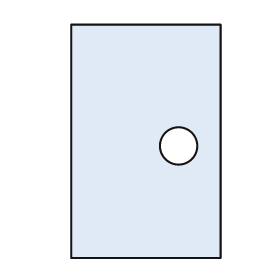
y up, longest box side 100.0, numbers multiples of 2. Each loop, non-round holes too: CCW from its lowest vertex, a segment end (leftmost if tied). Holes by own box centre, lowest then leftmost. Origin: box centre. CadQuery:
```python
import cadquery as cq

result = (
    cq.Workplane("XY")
    .moveTo(-32.0, -50.0)
    .lineTo(32.0, -50.0)
    .lineTo(32.0, 50.0)
    .lineTo(-32.0, 50.0)
    .close()
    .moveTo(14.0, -2.0)
    .circle(8.0)
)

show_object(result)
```